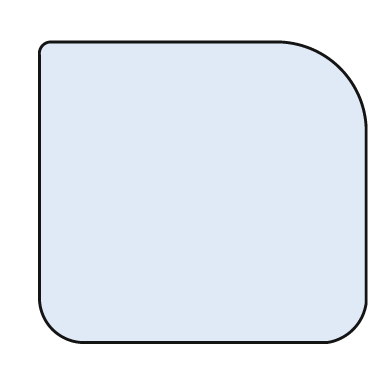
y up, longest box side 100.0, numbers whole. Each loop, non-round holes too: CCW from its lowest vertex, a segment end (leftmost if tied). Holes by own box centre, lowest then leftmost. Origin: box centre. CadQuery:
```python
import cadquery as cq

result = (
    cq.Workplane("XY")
    .moveTo(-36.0, -46.0)
    .lineTo(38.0, -46.0)
    .threePointArc((46.0, -42.0), (50.0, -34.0))
    .lineTo(50.0, 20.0)
    .threePointArc((42.0, 38.0), (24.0, 46.0))
    .lineTo(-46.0, 46.0)
    .threePointArc((-49.0, 45.0), (-50.0, 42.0))
    .lineTo(-50.0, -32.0)
    .threePointArc((-46.0, -42.0), (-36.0, -46.0))
    .close()
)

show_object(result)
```